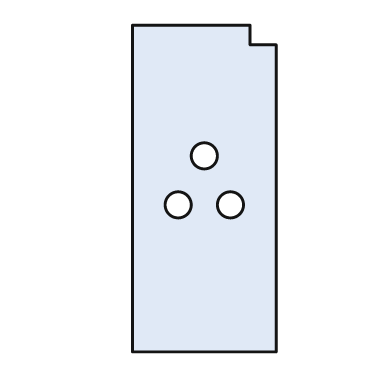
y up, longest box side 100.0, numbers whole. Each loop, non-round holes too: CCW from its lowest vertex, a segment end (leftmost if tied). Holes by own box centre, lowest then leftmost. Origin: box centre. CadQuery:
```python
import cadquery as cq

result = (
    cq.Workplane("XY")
    .moveTo(-22.0, -50.0)
    .lineTo(22.0, -50.0)
    .lineTo(22.0, 44.0)
    .lineTo(14.0, 44.0)
    .lineTo(14.0, 50.0)
    .lineTo(-22.0, 50.0)
    .close()
    .moveTo(-8.0, -5.0)
    .circle(4.0)
    .moveTo(8.0, -5.0)
    .circle(4.0)
    .moveTo(0.0, 10.0)
    .circle(4.0)
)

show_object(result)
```